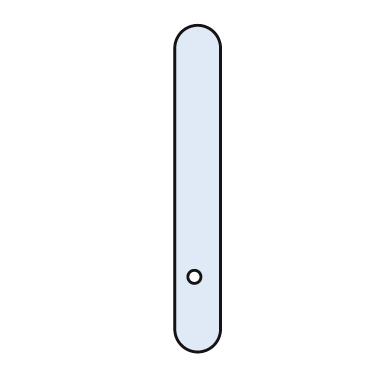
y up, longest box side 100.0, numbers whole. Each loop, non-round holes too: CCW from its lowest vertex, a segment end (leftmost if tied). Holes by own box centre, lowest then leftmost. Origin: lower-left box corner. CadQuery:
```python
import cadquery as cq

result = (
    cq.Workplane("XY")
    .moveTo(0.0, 7.0)
    .threePointArc((7.0, 0.0), (14.0, 7.0))
    .lineTo(14.0, 93.0)
    .threePointArc((7.0, 100.0), (0.0, 93.0))
    .close()
    .moveTo(6.0, 23.0)
    .circle(2.0)
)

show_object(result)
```